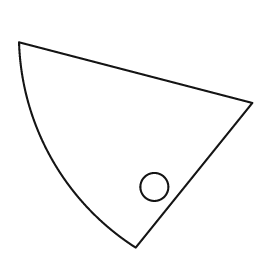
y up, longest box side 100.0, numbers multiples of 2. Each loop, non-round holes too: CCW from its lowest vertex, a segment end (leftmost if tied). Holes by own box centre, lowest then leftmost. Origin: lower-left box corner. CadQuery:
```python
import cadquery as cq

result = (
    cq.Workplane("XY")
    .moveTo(50.0, 0.0)
    .lineTo(100.0, 62.0)
    .lineTo(0.0, 88.0)
    .threePointArc((14.0, 38.0), (50.0, 0.0))
    .close()
    .moveTo(58.0, 26.0)
    .circle(6.0)
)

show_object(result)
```